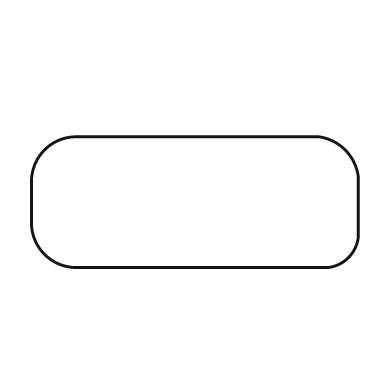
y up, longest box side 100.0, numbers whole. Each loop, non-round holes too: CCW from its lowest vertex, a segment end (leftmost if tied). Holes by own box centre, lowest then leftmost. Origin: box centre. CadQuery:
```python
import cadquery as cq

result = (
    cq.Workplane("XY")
    .moveTo(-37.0, -20.0)
    .lineTo(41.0, -20.0)
    .threePointArc((47.0, -17.0), (50.0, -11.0))
    .lineTo(50.0, 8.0)
    .threePointArc((46.0, 16.0), (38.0, 20.0))
    .lineTo(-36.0, 20.0)
    .threePointArc((-46.0, 16.0), (-50.0, 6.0))
    .lineTo(-50.0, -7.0)
    .threePointArc((-46.0, -16.0), (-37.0, -20.0))
    .close()
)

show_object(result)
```